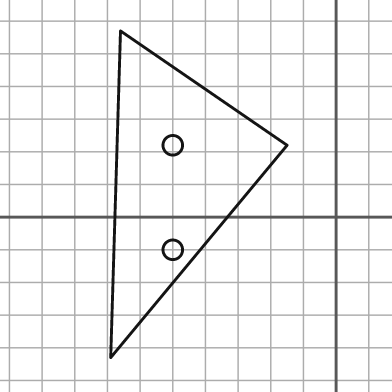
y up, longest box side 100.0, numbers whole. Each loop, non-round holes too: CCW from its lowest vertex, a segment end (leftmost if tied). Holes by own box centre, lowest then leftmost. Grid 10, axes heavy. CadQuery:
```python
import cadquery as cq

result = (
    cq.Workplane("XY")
    .moveTo(-69.0, -43.0)
    .lineTo(-15.0, 22.0)
    .lineTo(-66.0, 57.0)
    .close()
    .moveTo(-50.0, -10.0)
    .circle(3.0)
    .moveTo(-50.0, 22.0)
    .circle(3.0)
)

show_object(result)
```